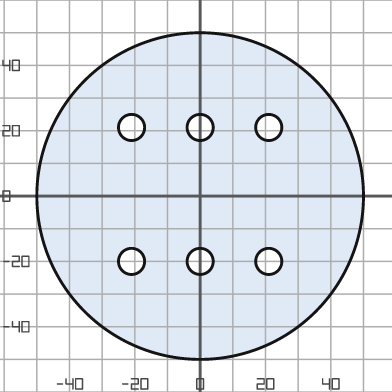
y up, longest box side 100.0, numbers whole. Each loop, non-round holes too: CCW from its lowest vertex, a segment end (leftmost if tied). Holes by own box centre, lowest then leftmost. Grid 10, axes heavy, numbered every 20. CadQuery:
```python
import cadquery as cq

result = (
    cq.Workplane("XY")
    .moveTo(0.0, 0.0)
    .circle(50.0)
    .moveTo(-21.0, -20.0)
    .circle(4.0)
    .moveTo(0.0, -20.0)
    .circle(4.0)
    .moveTo(21.0, -20.0)
    .circle(4.0)
    .moveTo(-21.0, 21.0)
    .circle(4.0)
    .moveTo(0.0, 21.0)
    .circle(4.0)
    .moveTo(21.0, 21.0)
    .circle(4.0)
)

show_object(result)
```